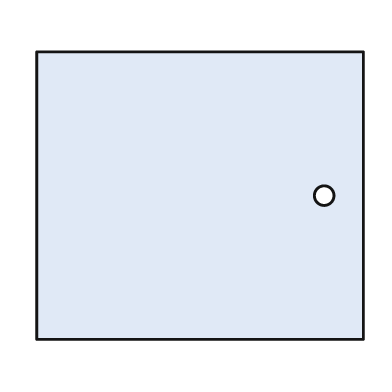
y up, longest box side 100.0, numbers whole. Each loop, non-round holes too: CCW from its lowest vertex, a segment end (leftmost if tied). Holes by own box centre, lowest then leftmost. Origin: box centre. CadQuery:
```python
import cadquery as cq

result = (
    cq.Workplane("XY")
    .moveTo(-50.0, -44.0)
    .lineTo(50.0, -44.0)
    .lineTo(50.0, 44.0)
    .lineTo(-50.0, 44.0)
    .close()
    .moveTo(38.0, 0.0)
    .circle(3.0)
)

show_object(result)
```